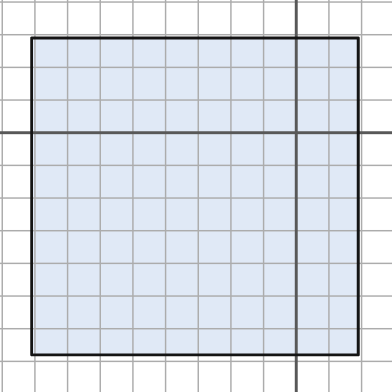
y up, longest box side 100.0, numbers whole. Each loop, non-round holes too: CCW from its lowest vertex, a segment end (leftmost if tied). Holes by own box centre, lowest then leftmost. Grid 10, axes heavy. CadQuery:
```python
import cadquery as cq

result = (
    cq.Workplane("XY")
    .moveTo(-81.0, -68.0)
    .lineTo(19.0, -68.0)
    .lineTo(19.0, 29.0)
    .lineTo(-81.0, 29.0)
    .close()
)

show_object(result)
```